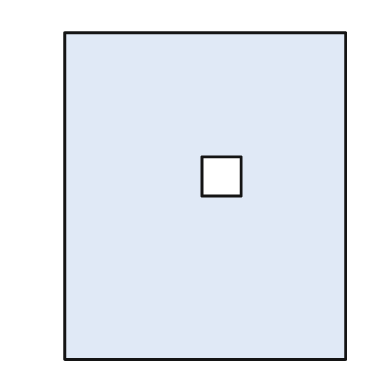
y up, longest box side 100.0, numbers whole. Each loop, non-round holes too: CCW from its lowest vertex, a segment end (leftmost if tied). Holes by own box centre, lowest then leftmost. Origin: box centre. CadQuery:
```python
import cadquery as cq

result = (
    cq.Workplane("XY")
    .moveTo(-43.0, -50.0)
    .lineTo(43.0, -50.0)
    .lineTo(43.0, 50.0)
    .lineTo(-43.0, 50.0)
    .close()
    .moveTo(-1.0, 0.0)
    .lineTo(11.0, 0.0)
    .lineTo(11.0, 12.0)
    .lineTo(-1.0, 12.0)
    .close()
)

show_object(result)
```